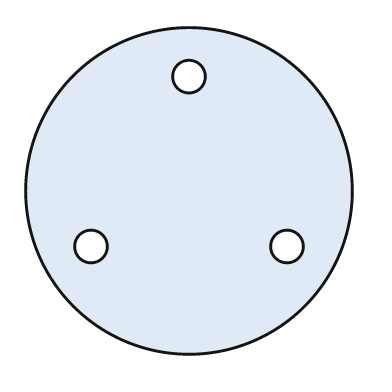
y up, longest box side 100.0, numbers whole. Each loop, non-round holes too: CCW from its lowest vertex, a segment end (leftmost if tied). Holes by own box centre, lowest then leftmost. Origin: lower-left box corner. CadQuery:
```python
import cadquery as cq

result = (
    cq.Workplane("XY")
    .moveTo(50.0, 50.0)
    .circle(50.0)
    .moveTo(20.0, 33.0)
    .circle(5.0)
    .moveTo(80.0, 33.0)
    .circle(5.0)
    .moveTo(50.0, 85.0)
    .circle(5.0)
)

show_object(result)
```